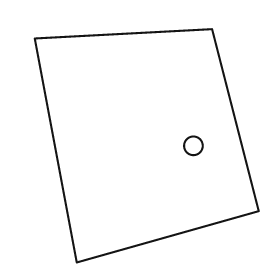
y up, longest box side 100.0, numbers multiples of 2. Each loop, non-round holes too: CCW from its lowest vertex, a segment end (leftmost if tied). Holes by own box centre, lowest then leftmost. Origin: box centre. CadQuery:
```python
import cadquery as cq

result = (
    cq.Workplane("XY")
    .moveTo(-30.0, -50.0)
    .lineTo(48.0, -28.0)
    .lineTo(28.0, 50.0)
    .lineTo(-48.0, 46.0)
    .close()
    .moveTo(20.0, 0.0)
    .circle(4.0)
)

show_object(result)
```